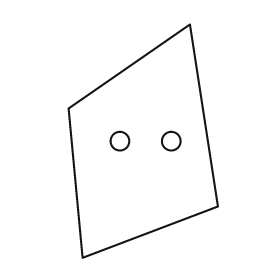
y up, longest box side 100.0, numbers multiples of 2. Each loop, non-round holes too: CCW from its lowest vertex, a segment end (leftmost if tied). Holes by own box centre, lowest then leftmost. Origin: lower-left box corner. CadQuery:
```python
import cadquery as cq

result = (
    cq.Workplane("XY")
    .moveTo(6.0, 0.0)
    .lineTo(64.0, 22.0)
    .lineTo(52.0, 100.0)
    .lineTo(0.0, 64.0)
    .close()
    .moveTo(22.0, 50.0)
    .circle(4.0)
    .moveTo(44.0, 50.0)
    .circle(4.0)
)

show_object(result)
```